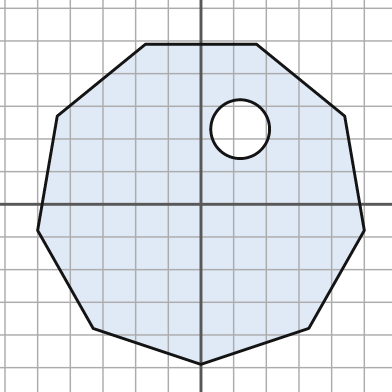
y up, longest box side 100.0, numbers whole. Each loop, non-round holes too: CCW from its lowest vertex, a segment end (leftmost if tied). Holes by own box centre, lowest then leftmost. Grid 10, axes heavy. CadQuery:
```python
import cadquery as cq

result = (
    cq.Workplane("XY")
    .moveTo(0.0, -49.0)
    .lineTo(33.0, -38.0)
    .lineTo(50.0, -8.0)
    .lineTo(44.0, 27.0)
    .lineTo(17.0, 49.0)
    .lineTo(-17.0, 49.0)
    .lineTo(-44.0, 27.0)
    .lineTo(-50.0, -8.0)
    .lineTo(-33.0, -38.0)
    .close()
    .moveTo(12.0, 23.0)
    .circle(9.0)
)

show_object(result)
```